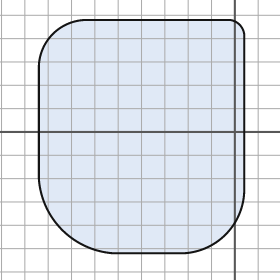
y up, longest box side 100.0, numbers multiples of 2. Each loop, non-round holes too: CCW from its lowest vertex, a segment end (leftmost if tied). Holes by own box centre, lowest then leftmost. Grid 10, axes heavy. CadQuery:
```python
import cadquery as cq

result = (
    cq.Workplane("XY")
    .moveTo(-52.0, -52.0)
    .lineTo(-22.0, -52.0)
    .threePointArc((-4.0, -44.0), (4.0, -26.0))
    .lineTo(4.0, 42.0)
    .threePointArc((2.0, 46.0), (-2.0, 48.0))
    .lineTo(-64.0, 48.0)
    .threePointArc((-78.0, 42.0), (-84.0, 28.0))
    .lineTo(-84.0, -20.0)
    .threePointArc((-74.0, -42.0), (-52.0, -52.0))
    .close()
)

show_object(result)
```